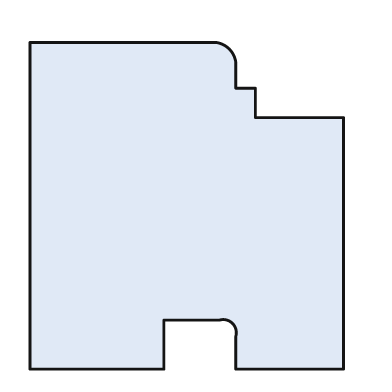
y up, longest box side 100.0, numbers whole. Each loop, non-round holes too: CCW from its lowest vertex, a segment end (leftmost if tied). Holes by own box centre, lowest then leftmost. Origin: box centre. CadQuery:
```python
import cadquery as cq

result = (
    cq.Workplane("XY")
    .moveTo(-48.0, -50.0)
    .lineTo(-7.0, -50.0)
    .lineTo(-7.0, -35.0)
    .lineTo(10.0, -35.0)
    .threePointArc((14.0, -36.0), (15.0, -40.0))
    .lineTo(15.0, -50.0)
    .lineTo(48.0, -50.0)
    .lineTo(48.0, 27.0)
    .lineTo(21.0, 27.0)
    .lineTo(21.0, 36.0)
    .lineTo(15.0, 36.0)
    .lineTo(15.0, 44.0)
    .threePointArc((13.0, 48.0), (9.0, 50.0))
    .lineTo(-48.0, 50.0)
    .close()
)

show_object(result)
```